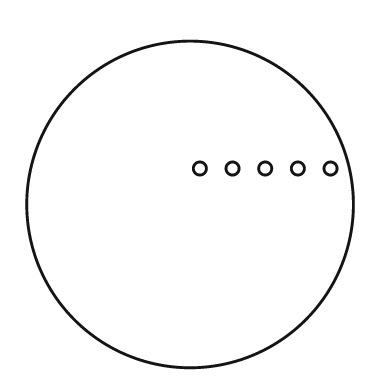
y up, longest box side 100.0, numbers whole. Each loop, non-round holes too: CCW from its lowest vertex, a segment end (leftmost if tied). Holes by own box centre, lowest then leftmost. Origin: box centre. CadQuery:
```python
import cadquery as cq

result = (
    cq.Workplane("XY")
    .moveTo(0.0, 0.0)
    .circle(50.0)
    .moveTo(3.0, 11.0)
    .circle(2.0)
    .moveTo(13.0, 11.0)
    .circle(2.0)
    .moveTo(23.0, 11.0)
    .circle(2.0)
    .moveTo(33.0, 11.0)
    .circle(2.0)
    .moveTo(43.0, 11.0)
    .circle(2.0)
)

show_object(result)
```